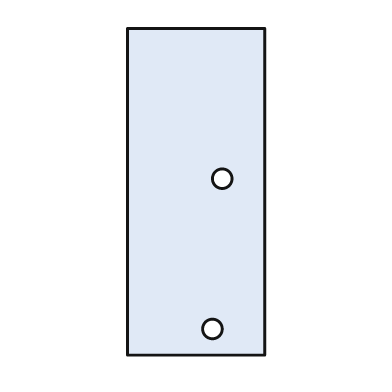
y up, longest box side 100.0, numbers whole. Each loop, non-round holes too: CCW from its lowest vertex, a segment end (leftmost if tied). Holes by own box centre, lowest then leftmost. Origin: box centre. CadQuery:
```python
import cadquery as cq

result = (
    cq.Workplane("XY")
    .moveTo(-21.0, -50.0)
    .lineTo(21.0, -50.0)
    .lineTo(21.0, 50.0)
    .lineTo(-21.0, 50.0)
    .close()
    .moveTo(5.0, -42.0)
    .circle(3.0)
    .moveTo(8.0, 4.0)
    .circle(3.0)
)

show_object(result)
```